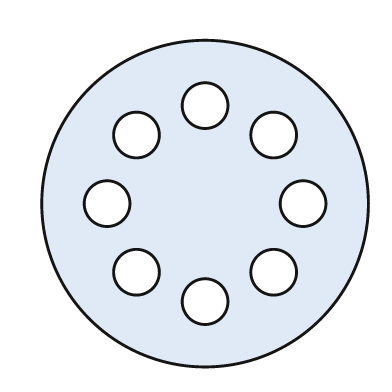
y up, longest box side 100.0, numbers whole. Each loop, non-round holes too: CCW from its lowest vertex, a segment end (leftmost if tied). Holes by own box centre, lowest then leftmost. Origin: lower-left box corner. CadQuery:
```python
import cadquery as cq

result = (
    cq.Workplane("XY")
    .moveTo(50.0, 50.0)
    .circle(50.0)
    .moveTo(50.0, 20.0)
    .circle(7.0)
    .moveTo(29.0, 29.0)
    .circle(7.0)
    .moveTo(71.0, 29.0)
    .circle(7.0)
    .moveTo(20.0, 50.0)
    .circle(7.0)
    .moveTo(80.0, 50.0)
    .circle(7.0)
    .moveTo(29.0, 71.0)
    .circle(7.0)
    .moveTo(71.0, 71.0)
    .circle(7.0)
    .moveTo(50.0, 80.0)
    .circle(7.0)
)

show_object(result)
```